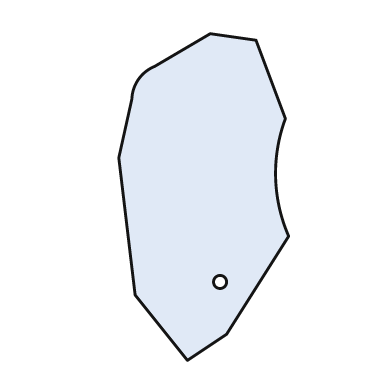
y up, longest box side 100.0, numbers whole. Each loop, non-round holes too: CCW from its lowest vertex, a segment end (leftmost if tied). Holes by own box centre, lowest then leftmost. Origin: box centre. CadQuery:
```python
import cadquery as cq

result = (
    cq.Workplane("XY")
    .moveTo(-5.0, -50.0)
    .lineTo(7.0, -42.0)
    .lineTo(26.0, -12.0)
    .threePointArc((22.0, 6.0), (25.0, 24.0))
    .lineTo(16.0, 48.0)
    .lineTo(2.0, 50.0)
    .lineTo(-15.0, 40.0)
    .threePointArc((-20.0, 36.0), (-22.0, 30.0))
    .lineTo(-26.0, 12.0)
    .lineTo(-21.0, -30.0)
    .close()
    .moveTo(5.0, -26.0)
    .circle(2.0)
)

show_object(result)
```